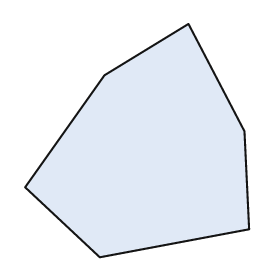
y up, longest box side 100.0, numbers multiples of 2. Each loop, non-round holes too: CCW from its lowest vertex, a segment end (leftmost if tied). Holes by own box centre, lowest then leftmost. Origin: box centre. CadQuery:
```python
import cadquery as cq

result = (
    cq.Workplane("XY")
    .moveTo(-16.0, -50.0)
    .lineTo(48.0, -38.0)
    .lineTo(46.0, 4.0)
    .lineTo(22.0, 50.0)
    .lineTo(-14.0, 28.0)
    .lineTo(-48.0, -20.0)
    .close()
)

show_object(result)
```